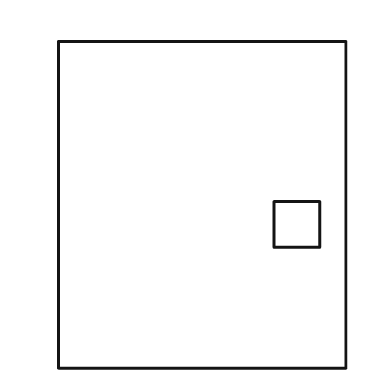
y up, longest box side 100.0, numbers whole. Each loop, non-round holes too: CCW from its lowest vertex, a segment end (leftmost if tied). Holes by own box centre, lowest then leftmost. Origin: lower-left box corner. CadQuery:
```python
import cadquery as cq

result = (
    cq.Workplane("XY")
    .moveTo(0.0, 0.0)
    .lineTo(88.0, 0.0)
    .lineTo(88.0, 100.0)
    .lineTo(0.0, 100.0)
    .close()
    .moveTo(66.0, 37.0)
    .lineTo(80.0, 37.0)
    .lineTo(80.0, 51.0)
    .lineTo(66.0, 51.0)
    .close()
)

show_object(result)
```